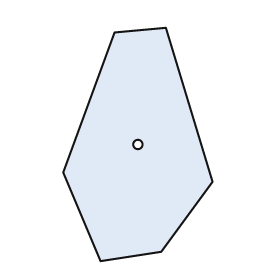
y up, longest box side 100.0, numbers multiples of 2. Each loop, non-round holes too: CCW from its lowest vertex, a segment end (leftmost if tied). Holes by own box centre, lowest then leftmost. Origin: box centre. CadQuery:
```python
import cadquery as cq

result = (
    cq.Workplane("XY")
    .moveTo(-16.0, -50.0)
    .lineTo(10.0, -46.0)
    .lineTo(32.0, -16.0)
    .lineTo(12.0, 50.0)
    .lineTo(-10.0, 48.0)
    .lineTo(-32.0, -12.0)
    .close()
    .moveTo(0.0, 0.0)
    .circle(2.0)
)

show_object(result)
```